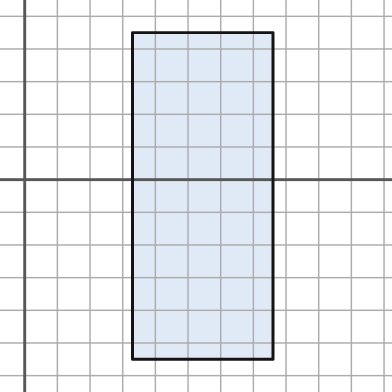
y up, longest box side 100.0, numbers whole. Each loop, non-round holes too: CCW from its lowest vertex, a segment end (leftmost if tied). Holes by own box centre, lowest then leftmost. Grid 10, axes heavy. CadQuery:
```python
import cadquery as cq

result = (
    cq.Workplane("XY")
    .moveTo(33.0, -55.0)
    .lineTo(76.0, -55.0)
    .lineTo(76.0, 45.0)
    .lineTo(33.0, 45.0)
    .close()
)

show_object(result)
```